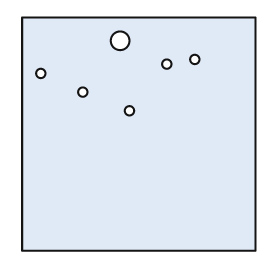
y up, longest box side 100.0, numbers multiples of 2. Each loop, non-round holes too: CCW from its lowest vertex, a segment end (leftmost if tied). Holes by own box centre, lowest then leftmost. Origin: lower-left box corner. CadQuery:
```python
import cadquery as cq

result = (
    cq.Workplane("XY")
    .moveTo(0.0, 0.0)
    .lineTo(100.0, 0.0)
    .lineTo(100.0, 100.0)
    .lineTo(0.0, 100.0)
    .close()
    .moveTo(46.0, 60.0)
    .circle(2.0)
    .moveTo(26.0, 68.0)
    .circle(2.0)
    .moveTo(8.0, 76.0)
    .circle(2.0)
    .moveTo(62.0, 80.0)
    .circle(2.0)
    .moveTo(74.0, 82.0)
    .circle(2.0)
    .moveTo(42.0, 90.0)
    .circle(4.0)
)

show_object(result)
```